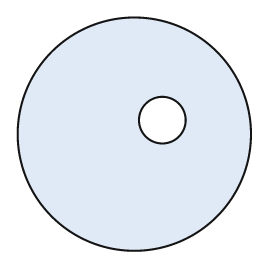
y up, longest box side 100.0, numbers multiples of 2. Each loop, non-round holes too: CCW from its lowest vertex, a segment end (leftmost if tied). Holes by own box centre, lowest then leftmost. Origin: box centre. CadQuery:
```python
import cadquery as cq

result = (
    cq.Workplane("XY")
    .moveTo(0.0, 0.0)
    .circle(50.0)
    .moveTo(12.0, 6.0)
    .circle(10.0)
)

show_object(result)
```